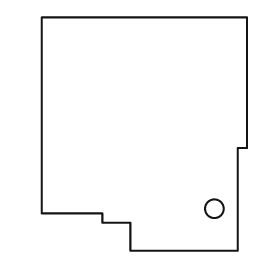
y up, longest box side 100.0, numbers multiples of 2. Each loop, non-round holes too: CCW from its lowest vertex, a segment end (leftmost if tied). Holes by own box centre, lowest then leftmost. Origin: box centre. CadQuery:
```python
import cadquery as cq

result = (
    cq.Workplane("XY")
    .moveTo(-6.0, -50.0)
    .lineTo(40.0, -50.0)
    .lineTo(40.0, -6.0)
    .lineTo(44.0, -6.0)
    .lineTo(44.0, 50.0)
    .lineTo(-44.0, 50.0)
    .lineTo(-44.0, -34.0)
    .lineTo(-18.0, -34.0)
    .lineTo(-18.0, -38.0)
    .lineTo(-6.0, -38.0)
    .close()
    .moveTo(30.0, -32.0)
    .circle(4.0)
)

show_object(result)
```